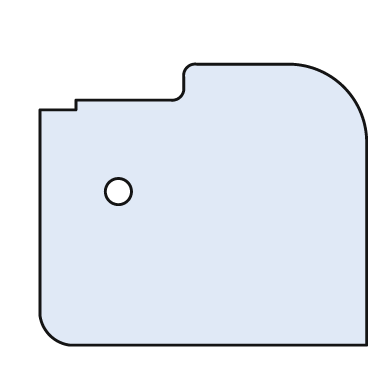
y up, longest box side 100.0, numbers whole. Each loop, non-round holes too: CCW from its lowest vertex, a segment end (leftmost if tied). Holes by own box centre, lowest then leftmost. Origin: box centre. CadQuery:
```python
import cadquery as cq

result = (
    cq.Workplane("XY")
    .moveTo(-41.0, -43.0)
    .lineTo(50.0, -43.0)
    .lineTo(50.0, 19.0)
    .threePointArc((43.0, 36.0), (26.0, 43.0))
    .lineTo(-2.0, 43.0)
    .threePointArc((-5.0, 42.0), (-6.0, 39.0))
    .lineTo(-6.0, 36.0)
    .threePointArc((-7.0, 33.0), (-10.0, 32.0))
    .lineTo(-39.0, 32.0)
    .lineTo(-39.0, 29.0)
    .lineTo(-50.0, 29.0)
    .lineTo(-50.0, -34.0)
    .threePointArc((-47.0, -40.0), (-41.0, -43.0))
    .close()
    .moveTo(-26.0, 4.0)
    .circle(4.0)
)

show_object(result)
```